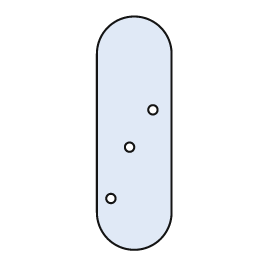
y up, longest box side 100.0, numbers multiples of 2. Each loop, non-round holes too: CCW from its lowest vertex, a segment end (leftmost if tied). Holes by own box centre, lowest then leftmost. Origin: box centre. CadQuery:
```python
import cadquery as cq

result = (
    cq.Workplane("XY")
    .moveTo(-16.0, -34.0)
    .threePointArc((0.0, -50.0), (16.0, -34.0))
    .lineTo(16.0, 34.0)
    .threePointArc((0.0, 50.0), (-16.0, 34.0))
    .close()
    .moveTo(-10.0, -28.0)
    .circle(2.0)
    .moveTo(-2.0, -6.0)
    .circle(2.0)
    .moveTo(8.0, 10.0)
    .circle(2.0)
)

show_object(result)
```